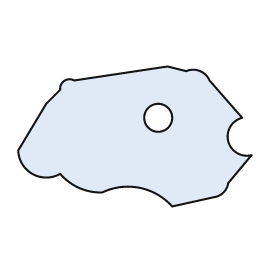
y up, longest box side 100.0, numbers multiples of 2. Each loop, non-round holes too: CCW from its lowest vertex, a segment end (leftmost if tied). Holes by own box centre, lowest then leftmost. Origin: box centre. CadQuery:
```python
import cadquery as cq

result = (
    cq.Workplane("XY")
    .moveTo(16.0, -30.0)
    .lineTo(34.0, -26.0)
    .threePointArc((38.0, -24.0), (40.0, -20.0))
    .lineTo(50.0, -8.0)
    .threePointArc((40.0, -2.0), (46.0, 8.0))
    .lineTo(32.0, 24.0)
    .threePointArc((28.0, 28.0), (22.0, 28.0))
    .lineTo(14.0, 30.0)
    .lineTo(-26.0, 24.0)
    .threePointArc((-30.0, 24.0), (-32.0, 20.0))
    .lineTo(-38.0, 14.0)
    .lineTo(-50.0, -6.0)
    .threePointArc((-44.0, -16.0), (-32.0, -16.0))
    .threePointArc((-24.0, -22.0), (-14.0, -24.0))
    .threePointArc((2.0, -22.0), (16.0, -30.0))
    .close()
    .moveTo(10.0, 8.0)
    .circle(6.0)
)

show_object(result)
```